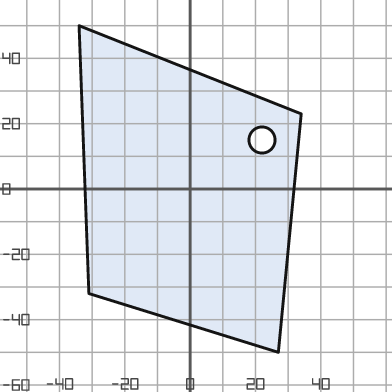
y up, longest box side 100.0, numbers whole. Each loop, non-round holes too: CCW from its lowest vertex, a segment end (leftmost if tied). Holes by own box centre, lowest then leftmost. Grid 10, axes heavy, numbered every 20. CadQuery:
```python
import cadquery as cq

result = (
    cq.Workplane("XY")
    .moveTo(27.0, -50.0)
    .lineTo(34.0, 23.0)
    .lineTo(-34.0, 50.0)
    .lineTo(-31.0, -32.0)
    .close()
    .moveTo(22.0, 15.0)
    .circle(4.0)
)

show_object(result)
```